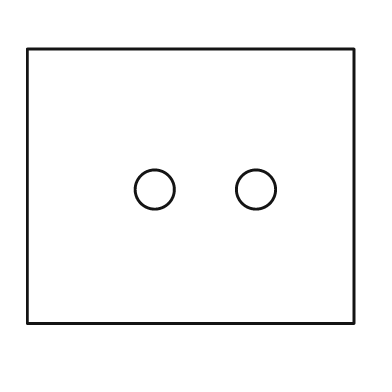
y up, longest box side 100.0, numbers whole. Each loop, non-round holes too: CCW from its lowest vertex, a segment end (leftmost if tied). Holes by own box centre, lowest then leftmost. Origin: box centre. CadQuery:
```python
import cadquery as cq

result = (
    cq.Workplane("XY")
    .moveTo(-50.0, -42.0)
    .lineTo(50.0, -42.0)
    .lineTo(50.0, 42.0)
    .lineTo(-50.0, 42.0)
    .close()
    .moveTo(-11.0, -1.0)
    .circle(6.0)
    .moveTo(20.0, -1.0)
    .circle(6.0)
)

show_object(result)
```